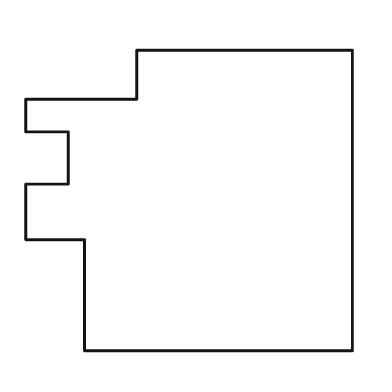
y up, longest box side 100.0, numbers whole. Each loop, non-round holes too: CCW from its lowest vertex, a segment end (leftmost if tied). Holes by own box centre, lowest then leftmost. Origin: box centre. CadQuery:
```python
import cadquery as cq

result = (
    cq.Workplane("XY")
    .moveTo(-32.0, -46.0)
    .lineTo(50.0, -46.0)
    .lineTo(50.0, 46.0)
    .lineTo(-16.0, 46.0)
    .lineTo(-16.0, 31.0)
    .lineTo(-50.0, 31.0)
    .lineTo(-50.0, 21.0)
    .lineTo(-37.0, 21.0)
    .lineTo(-37.0, 5.0)
    .lineTo(-50.0, 5.0)
    .lineTo(-50.0, -12.0)
    .lineTo(-32.0, -12.0)
    .close()
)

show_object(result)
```